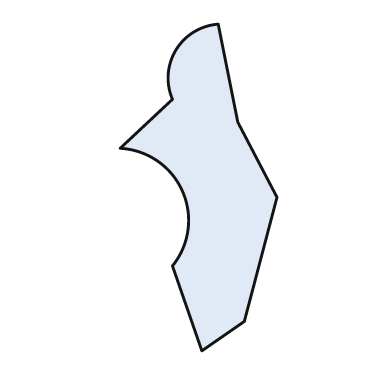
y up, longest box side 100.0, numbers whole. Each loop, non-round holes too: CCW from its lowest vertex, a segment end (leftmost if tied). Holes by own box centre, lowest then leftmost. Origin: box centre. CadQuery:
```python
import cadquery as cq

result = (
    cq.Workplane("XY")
    .moveTo(1.0, -50.0)
    .lineTo(14.0, -41.0)
    .lineTo(24.0, -3.0)
    .lineTo(12.0, 20.0)
    .lineTo(6.0, 50.0)
    .threePointArc((-7.0, 42.0), (-8.0, 27.0))
    .lineTo(-24.0, 12.0)
    .threePointArc((-5.0, -1.0), (-8.0, -24.0))
    .close()
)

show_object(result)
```